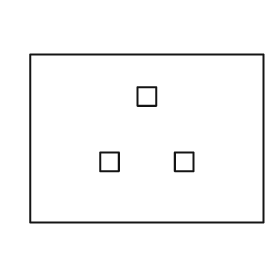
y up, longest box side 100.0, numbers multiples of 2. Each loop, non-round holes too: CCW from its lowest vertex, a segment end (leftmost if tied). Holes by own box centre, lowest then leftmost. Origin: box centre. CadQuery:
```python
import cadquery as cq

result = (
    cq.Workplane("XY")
    .moveTo(-50.0, -36.0)
    .lineTo(50.0, -36.0)
    .lineTo(50.0, 36.0)
    .lineTo(-50.0, 36.0)
    .close()
    .moveTo(-20.0, -14.0)
    .lineTo(-12.0, -14.0)
    .lineTo(-12.0, -6.0)
    .lineTo(-20.0, -6.0)
    .close()
    .moveTo(12.0, -14.0)
    .lineTo(20.0, -14.0)
    .lineTo(20.0, -6.0)
    .lineTo(12.0, -6.0)
    .close()
    .moveTo(-4.0, 14.0)
    .lineTo(4.0, 14.0)
    .lineTo(4.0, 22.0)
    .lineTo(-4.0, 22.0)
    .close()
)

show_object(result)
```